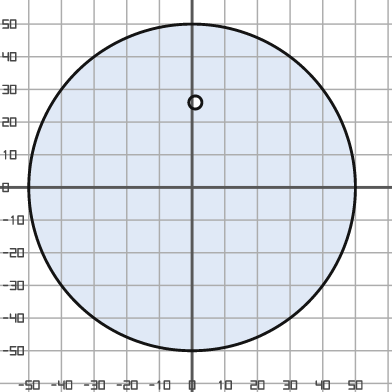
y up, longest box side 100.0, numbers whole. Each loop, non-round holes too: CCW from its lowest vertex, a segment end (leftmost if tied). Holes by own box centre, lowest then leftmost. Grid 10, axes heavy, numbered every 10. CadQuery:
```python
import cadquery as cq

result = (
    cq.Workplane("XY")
    .moveTo(0.0, 0.0)
    .circle(50.0)
    .moveTo(1.0, 26.0)
    .circle(2.0)
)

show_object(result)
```